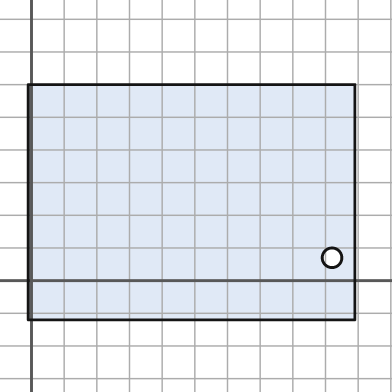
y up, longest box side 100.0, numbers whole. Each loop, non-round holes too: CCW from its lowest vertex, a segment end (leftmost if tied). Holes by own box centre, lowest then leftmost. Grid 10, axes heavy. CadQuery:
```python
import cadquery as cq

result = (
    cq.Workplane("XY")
    .moveTo(-1.0, -12.0)
    .lineTo(99.0, -12.0)
    .lineTo(99.0, 60.0)
    .lineTo(-1.0, 60.0)
    .close()
    .moveTo(92.0, 7.0)
    .circle(3.0)
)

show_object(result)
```